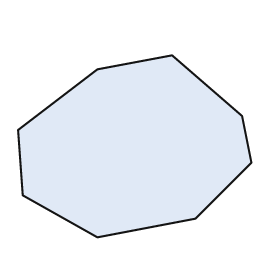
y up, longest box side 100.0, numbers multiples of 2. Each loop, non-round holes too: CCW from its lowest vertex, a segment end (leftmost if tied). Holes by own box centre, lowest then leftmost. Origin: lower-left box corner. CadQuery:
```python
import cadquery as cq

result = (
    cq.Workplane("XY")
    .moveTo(34.0, 0.0)
    .lineTo(76.0, 8.0)
    .lineTo(100.0, 32.0)
    .lineTo(96.0, 52.0)
    .lineTo(66.0, 78.0)
    .lineTo(34.0, 72.0)
    .lineTo(0.0, 46.0)
    .lineTo(2.0, 18.0)
    .close()
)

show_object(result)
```